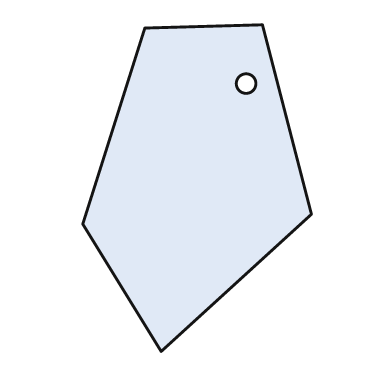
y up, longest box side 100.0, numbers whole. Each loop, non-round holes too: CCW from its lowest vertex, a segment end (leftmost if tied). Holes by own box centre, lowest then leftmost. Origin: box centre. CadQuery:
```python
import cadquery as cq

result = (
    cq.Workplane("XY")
    .moveTo(-11.0, -50.0)
    .lineTo(35.0, -8.0)
    .lineTo(20.0, 50.0)
    .lineTo(-16.0, 49.0)
    .lineTo(-35.0, -11.0)
    .close()
    .moveTo(15.0, 32.0)
    .circle(3.0)
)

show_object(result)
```